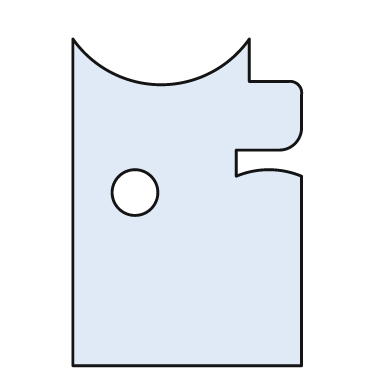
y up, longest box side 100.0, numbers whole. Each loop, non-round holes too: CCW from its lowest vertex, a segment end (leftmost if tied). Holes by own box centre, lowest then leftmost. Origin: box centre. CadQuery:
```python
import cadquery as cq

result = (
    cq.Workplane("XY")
    .moveTo(-35.0, -50.0)
    .lineTo(35.0, -50.0)
    .lineTo(35.0, 8.0)
    .threePointArc((25.0, 10.0), (15.0, 8.0))
    .lineTo(15.0, 16.0)
    .lineTo(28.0, 16.0)
    .threePointArc((33.0, 18.0), (35.0, 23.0))
    .lineTo(35.0, 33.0)
    .threePointArc((34.0, 36.0), (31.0, 37.0))
    .lineTo(19.0, 37.0)
    .lineTo(19.0, 50.0)
    .threePointArc((-8.0, 36.0), (-35.0, 50.0))
    .close()
    .moveTo(-16.0, 3.0)
    .circle(7.0)
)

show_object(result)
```